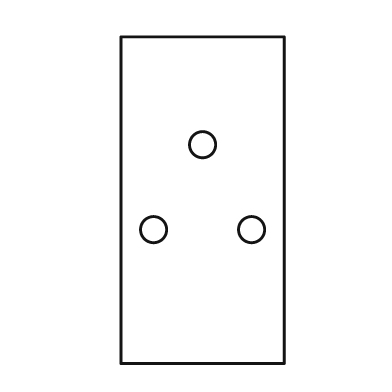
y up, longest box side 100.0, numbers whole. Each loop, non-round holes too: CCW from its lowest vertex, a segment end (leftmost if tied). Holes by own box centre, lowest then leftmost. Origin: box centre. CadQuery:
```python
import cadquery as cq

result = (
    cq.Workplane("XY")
    .moveTo(-25.0, -50.0)
    .lineTo(25.0, -50.0)
    .lineTo(25.0, 50.0)
    .lineTo(-25.0, 50.0)
    .close()
    .moveTo(-15.0, -9.0)
    .circle(4.0)
    .moveTo(15.0, -9.0)
    .circle(4.0)
    .moveTo(0.0, 17.0)
    .circle(4.0)
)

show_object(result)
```